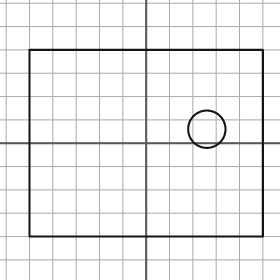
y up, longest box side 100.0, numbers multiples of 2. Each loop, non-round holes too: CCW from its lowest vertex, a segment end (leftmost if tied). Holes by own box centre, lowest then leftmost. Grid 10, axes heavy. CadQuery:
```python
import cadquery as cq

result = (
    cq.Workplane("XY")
    .moveTo(-50.0, -40.0)
    .lineTo(50.0, -40.0)
    .lineTo(50.0, 40.0)
    .lineTo(-50.0, 40.0)
    .close()
    .moveTo(26.0, 6.0)
    .circle(8.0)
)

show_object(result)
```